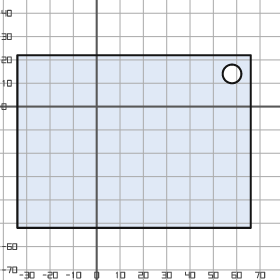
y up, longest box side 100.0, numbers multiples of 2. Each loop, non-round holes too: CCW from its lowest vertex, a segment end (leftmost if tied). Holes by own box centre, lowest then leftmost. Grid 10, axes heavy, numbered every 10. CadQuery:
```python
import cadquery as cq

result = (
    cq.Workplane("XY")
    .moveTo(-34.0, -52.0)
    .lineTo(66.0, -52.0)
    .lineTo(66.0, 22.0)
    .lineTo(-34.0, 22.0)
    .close()
    .moveTo(58.0, 14.0)
    .circle(4.0)
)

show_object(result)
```